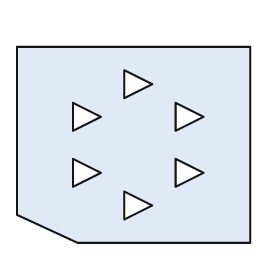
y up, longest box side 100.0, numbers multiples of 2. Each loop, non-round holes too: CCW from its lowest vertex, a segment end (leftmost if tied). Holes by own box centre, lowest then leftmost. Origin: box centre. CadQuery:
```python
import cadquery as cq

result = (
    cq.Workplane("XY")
    .moveTo(-24.0, -42.0)
    .lineTo(50.0, -42.0)
    .lineTo(50.0, 42.0)
    .lineTo(-50.0, 42.0)
    .lineTo(-50.0, -30.0)
    .close()
    .moveTo(-4.0, -32.0)
    .lineTo(8.0, -26.0)
    .lineTo(-4.0, -20.0)
    .close()
    .moveTo(-26.0, -18.0)
    .lineTo(-14.0, -12.0)
    .lineTo(-26.0, -6.0)
    .close()
    .moveTo(18.0, -18.0)
    .lineTo(30.0, -12.0)
    .lineTo(18.0, -6.0)
    .close()
    .moveTo(-26.0, 6.0)
    .lineTo(-14.0, 12.0)
    .lineTo(-26.0, 18.0)
    .close()
    .moveTo(18.0, 6.0)
    .lineTo(30.0, 12.0)
    .lineTo(18.0, 18.0)
    .close()
    .moveTo(-4.0, 20.0)
    .lineTo(8.0, 26.0)
    .lineTo(-4.0, 32.0)
    .close()
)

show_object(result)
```